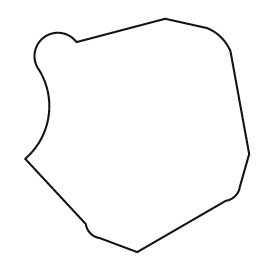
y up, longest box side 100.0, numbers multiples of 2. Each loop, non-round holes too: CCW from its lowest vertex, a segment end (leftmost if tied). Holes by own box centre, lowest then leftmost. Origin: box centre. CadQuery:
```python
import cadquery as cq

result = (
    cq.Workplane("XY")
    .moveTo(0.0, -50.0)
    .lineTo(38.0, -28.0)
    .threePointArc((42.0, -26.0), (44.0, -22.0))
    .lineTo(48.0, -8.0)
    .lineTo(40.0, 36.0)
    .threePointArc((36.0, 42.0), (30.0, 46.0))
    .lineTo(12.0, 50.0)
    .lineTo(-26.0, 40.0)
    .threePointArc((-40.0, 42.0), (-42.0, 28.0))
    .threePointArc((-38.0, 8.0), (-48.0, -10.0))
    .lineTo(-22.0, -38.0)
    .threePointArc((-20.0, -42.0), (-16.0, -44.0))
    .close()
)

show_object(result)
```